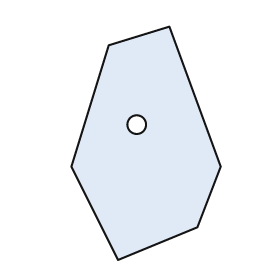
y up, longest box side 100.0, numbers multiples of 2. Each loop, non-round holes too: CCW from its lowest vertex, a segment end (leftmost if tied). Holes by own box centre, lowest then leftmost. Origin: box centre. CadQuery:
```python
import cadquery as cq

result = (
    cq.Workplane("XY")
    .moveTo(-12.0, -50.0)
    .lineTo(22.0, -36.0)
    .lineTo(32.0, -10.0)
    .lineTo(10.0, 50.0)
    .lineTo(-16.0, 42.0)
    .lineTo(-32.0, -10.0)
    .close()
    .moveTo(-4.0, 8.0)
    .circle(4.0)
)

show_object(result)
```